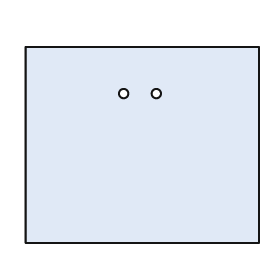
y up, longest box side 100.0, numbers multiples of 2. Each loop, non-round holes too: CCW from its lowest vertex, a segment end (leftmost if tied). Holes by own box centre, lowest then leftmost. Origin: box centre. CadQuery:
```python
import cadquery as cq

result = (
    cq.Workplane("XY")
    .moveTo(-50.0, -42.0)
    .lineTo(50.0, -42.0)
    .lineTo(50.0, 42.0)
    .lineTo(-50.0, 42.0)
    .close()
    .moveTo(-8.0, 22.0)
    .circle(2.0)
    .moveTo(6.0, 22.0)
    .circle(2.0)
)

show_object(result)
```